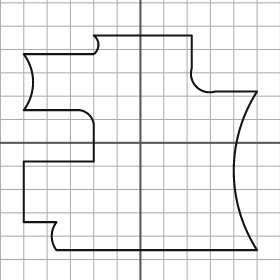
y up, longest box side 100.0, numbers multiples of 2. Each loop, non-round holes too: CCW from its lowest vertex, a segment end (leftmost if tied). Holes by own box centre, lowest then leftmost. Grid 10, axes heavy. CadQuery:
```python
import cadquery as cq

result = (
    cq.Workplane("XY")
    .moveTo(-36.0, -46.0)
    .lineTo(50.0, -46.0)
    .threePointArc((40.0, -12.0), (50.0, 22.0))
    .lineTo(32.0, 22.0)
    .threePointArc((24.0, 24.0), (22.0, 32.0))
    .lineTo(22.0, 46.0)
    .lineTo(-20.0, 46.0)
    .threePointArc((-18.0, 42.0), (-20.0, 38.0))
    .lineTo(-50.0, 38.0)
    .threePointArc((-46.0, 26.0), (-50.0, 14.0))
    .lineTo(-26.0, 14.0)
    .threePointArc((-22.0, 12.0), (-20.0, 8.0))
    .lineTo(-20.0, -8.0)
    .lineTo(-50.0, -8.0)
    .lineTo(-50.0, -34.0)
    .lineTo(-36.0, -34.0)
    .threePointArc((-38.0, -40.0), (-36.0, -46.0))
    .close()
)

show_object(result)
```